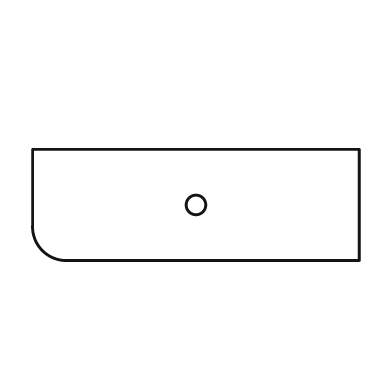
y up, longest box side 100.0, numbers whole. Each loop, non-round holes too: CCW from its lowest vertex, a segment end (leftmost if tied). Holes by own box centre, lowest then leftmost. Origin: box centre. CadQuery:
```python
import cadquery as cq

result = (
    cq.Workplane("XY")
    .moveTo(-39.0, -17.0)
    .lineTo(50.0, -17.0)
    .lineTo(50.0, 17.0)
    .lineTo(-50.0, 17.0)
    .lineTo(-50.0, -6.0)
    .threePointArc((-47.0, -14.0), (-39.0, -17.0))
    .close()
    .moveTo(0.0, 0.0)
    .circle(3.0)
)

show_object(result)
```